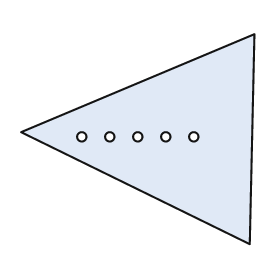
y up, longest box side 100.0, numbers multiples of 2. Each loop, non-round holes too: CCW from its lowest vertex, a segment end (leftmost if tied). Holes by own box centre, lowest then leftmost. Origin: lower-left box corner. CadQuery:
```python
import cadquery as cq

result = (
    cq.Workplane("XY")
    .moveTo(98.0, 0.0)
    .lineTo(100.0, 90.0)
    .lineTo(0.0, 48.0)
    .close()
    .moveTo(26.0, 46.0)
    .circle(2.0)
    .moveTo(38.0, 46.0)
    .circle(2.0)
    .moveTo(50.0, 46.0)
    .circle(2.0)
    .moveTo(62.0, 46.0)
    .circle(2.0)
    .moveTo(74.0, 46.0)
    .circle(2.0)
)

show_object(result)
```